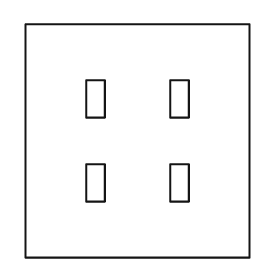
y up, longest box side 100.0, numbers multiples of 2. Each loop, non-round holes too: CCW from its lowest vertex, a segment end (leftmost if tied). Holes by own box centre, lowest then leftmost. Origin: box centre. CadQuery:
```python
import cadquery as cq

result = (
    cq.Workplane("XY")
    .moveTo(-48.0, -50.0)
    .lineTo(48.0, -50.0)
    .lineTo(48.0, 50.0)
    .lineTo(-48.0, 50.0)
    .close()
    .moveTo(-22.0, -26.0)
    .lineTo(-14.0, -26.0)
    .lineTo(-14.0, -10.0)
    .lineTo(-22.0, -10.0)
    .close()
    .moveTo(14.0, -26.0)
    .lineTo(22.0, -26.0)
    .lineTo(22.0, -10.0)
    .lineTo(14.0, -10.0)
    .close()
    .moveTo(-22.0, 10.0)
    .lineTo(-14.0, 10.0)
    .lineTo(-14.0, 26.0)
    .lineTo(-22.0, 26.0)
    .close()
    .moveTo(14.0, 10.0)
    .lineTo(22.0, 10.0)
    .lineTo(22.0, 26.0)
    .lineTo(14.0, 26.0)
    .close()
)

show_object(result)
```